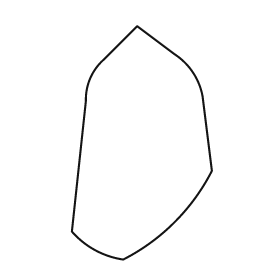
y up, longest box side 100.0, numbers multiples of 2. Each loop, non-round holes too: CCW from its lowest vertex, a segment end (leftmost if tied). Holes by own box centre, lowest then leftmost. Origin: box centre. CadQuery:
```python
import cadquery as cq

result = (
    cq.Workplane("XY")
    .moveTo(-8.0, -50.0)
    .threePointArc((14.0, -34.0), (30.0, -12.0))
    .lineTo(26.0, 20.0)
    .threePointArc((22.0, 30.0), (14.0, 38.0))
    .lineTo(-2.0, 50.0)
    .lineTo(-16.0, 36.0)
    .threePointArc((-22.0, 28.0), (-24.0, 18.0))
    .lineTo(-30.0, -38.0)
    .threePointArc((-20.0, -46.0), (-8.0, -50.0))
    .close()
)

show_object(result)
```